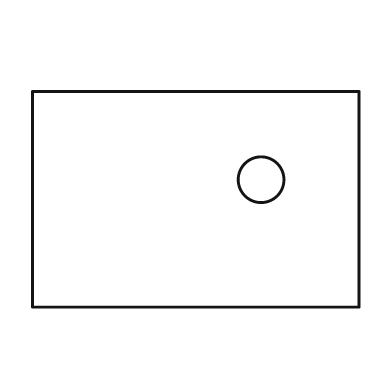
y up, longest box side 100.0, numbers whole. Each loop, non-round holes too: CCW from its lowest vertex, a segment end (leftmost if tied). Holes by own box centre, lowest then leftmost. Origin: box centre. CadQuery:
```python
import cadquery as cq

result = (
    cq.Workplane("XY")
    .moveTo(-50.0, -33.0)
    .lineTo(50.0, -33.0)
    .lineTo(50.0, 33.0)
    .lineTo(-50.0, 33.0)
    .close()
    .moveTo(20.0, 6.0)
    .circle(7.0)
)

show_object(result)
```